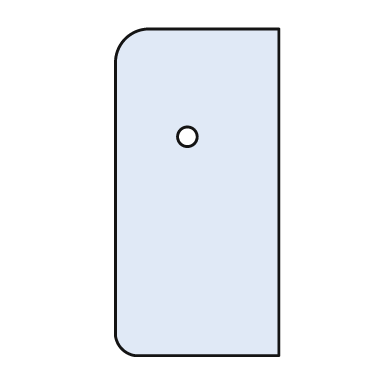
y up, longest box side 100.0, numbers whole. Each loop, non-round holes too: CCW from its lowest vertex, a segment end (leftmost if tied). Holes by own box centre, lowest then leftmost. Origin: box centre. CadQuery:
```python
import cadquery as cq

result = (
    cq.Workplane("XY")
    .moveTo(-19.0, -50.0)
    .lineTo(25.0, -50.0)
    .lineTo(25.0, 50.0)
    .lineTo(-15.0, 50.0)
    .threePointArc((-22.0, 47.0), (-25.0, 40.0))
    .lineTo(-25.0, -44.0)
    .threePointArc((-23.0, -48.0), (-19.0, -50.0))
    .close()
    .moveTo(-3.0, 17.0)
    .circle(3.0)
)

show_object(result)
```